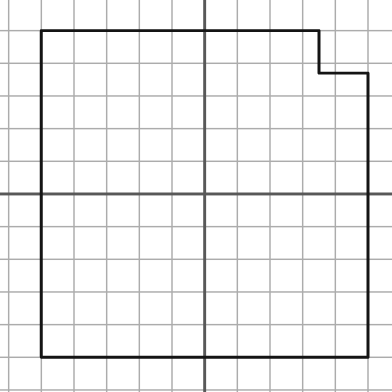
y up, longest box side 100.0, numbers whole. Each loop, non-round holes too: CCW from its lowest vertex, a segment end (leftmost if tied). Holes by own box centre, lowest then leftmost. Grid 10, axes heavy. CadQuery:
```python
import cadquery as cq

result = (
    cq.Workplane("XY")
    .moveTo(-50.0, -50.0)
    .lineTo(50.0, -50.0)
    .lineTo(50.0, 37.0)
    .lineTo(35.0, 37.0)
    .lineTo(35.0, 50.0)
    .lineTo(-50.0, 50.0)
    .close()
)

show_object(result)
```